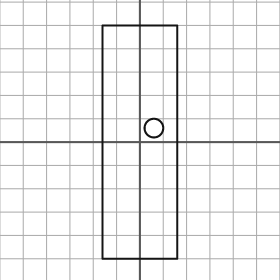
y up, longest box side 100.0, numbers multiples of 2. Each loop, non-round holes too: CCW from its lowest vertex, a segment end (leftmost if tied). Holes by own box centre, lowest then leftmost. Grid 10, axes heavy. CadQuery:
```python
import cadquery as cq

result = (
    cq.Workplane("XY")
    .moveTo(-16.0, -50.0)
    .lineTo(16.0, -50.0)
    .lineTo(16.0, 50.0)
    .lineTo(-16.0, 50.0)
    .close()
    .moveTo(6.0, 6.0)
    .circle(4.0)
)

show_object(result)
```